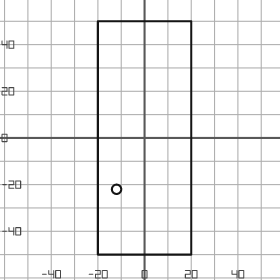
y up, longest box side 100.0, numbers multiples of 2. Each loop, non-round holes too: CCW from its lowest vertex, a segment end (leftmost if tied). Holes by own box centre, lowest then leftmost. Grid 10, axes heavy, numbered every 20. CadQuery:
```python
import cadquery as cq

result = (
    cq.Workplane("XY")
    .moveTo(-20.0, -50.0)
    .lineTo(20.0, -50.0)
    .lineTo(20.0, 50.0)
    .lineTo(-20.0, 50.0)
    .close()
    .moveTo(-12.0, -22.0)
    .circle(2.0)
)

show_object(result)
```